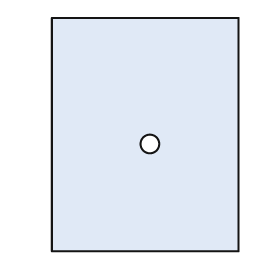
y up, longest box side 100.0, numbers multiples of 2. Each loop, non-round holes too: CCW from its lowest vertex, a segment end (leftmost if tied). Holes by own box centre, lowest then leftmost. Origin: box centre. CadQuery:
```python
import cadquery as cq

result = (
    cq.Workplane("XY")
    .moveTo(-40.0, -50.0)
    .lineTo(40.0, -50.0)
    .lineTo(40.0, 50.0)
    .lineTo(-40.0, 50.0)
    .close()
    .moveTo(2.0, -4.0)
    .circle(4.0)
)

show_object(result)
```